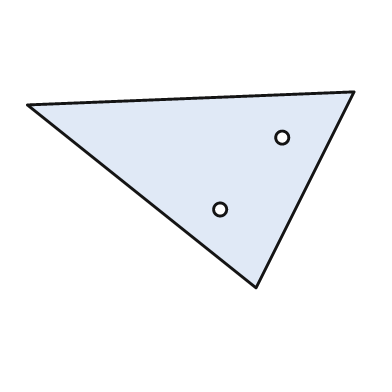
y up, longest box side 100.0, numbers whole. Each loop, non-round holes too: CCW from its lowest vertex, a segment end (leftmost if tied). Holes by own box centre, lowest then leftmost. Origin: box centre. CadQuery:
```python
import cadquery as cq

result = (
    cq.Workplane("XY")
    .moveTo(20.0, -30.0)
    .lineTo(50.0, 30.0)
    .lineTo(-50.0, 26.0)
    .close()
    .moveTo(9.0, -6.0)
    .circle(2.0)
    .moveTo(28.0, 16.0)
    .circle(2.0)
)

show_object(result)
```